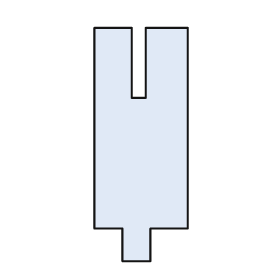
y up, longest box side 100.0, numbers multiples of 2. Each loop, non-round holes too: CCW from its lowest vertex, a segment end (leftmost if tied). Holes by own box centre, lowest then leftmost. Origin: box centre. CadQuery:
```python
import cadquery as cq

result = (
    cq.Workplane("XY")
    .moveTo(-8.0, -50.0)
    .lineTo(4.0, -50.0)
    .lineTo(4.0, -36.0)
    .lineTo(20.0, -36.0)
    .lineTo(20.0, 50.0)
    .lineTo(2.0, 50.0)
    .lineTo(2.0, 20.0)
    .lineTo(-4.0, 20.0)
    .lineTo(-4.0, 50.0)
    .lineTo(-20.0, 50.0)
    .lineTo(-20.0, -36.0)
    .lineTo(-8.0, -36.0)
    .close()
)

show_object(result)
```